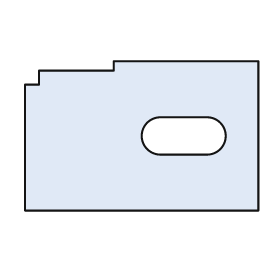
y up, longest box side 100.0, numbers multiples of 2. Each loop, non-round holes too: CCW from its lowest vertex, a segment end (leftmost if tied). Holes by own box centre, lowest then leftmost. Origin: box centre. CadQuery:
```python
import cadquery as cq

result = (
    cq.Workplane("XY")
    .moveTo(-50.0, -32.0)
    .lineTo(50.0, -32.0)
    .lineTo(50.0, 32.0)
    .lineTo(-12.0, 32.0)
    .lineTo(-12.0, 28.0)
    .lineTo(-44.0, 28.0)
    .lineTo(-44.0, 22.0)
    .lineTo(-50.0, 22.0)
    .close()
    .moveTo(8.0, -8.0)
    .lineTo(28.0, -8.0)
    .threePointArc((36.0, 0.0), (28.0, 8.0))
    .lineTo(8.0, 8.0)
    .threePointArc((0.0, 0.0), (8.0, -8.0))
    .close()
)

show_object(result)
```